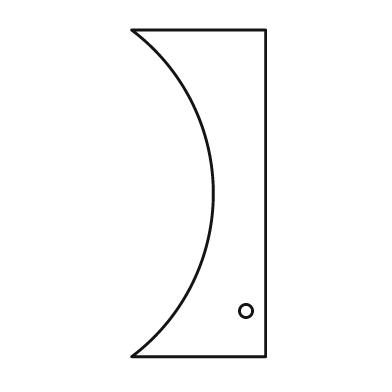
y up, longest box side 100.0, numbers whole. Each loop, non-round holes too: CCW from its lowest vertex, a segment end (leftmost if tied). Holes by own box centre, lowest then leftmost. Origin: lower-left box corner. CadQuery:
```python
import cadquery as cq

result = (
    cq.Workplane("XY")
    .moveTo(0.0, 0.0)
    .lineTo(41.0, 0.0)
    .lineTo(41.0, 100.0)
    .lineTo(0.0, 100.0)
    .threePointArc((25.0, 50.0), (0.0, 0.0))
    .close()
    .moveTo(35.0, 14.0)
    .circle(2.0)
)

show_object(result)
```